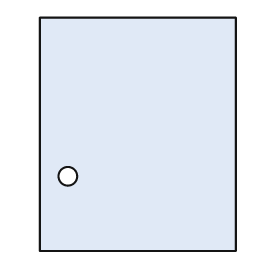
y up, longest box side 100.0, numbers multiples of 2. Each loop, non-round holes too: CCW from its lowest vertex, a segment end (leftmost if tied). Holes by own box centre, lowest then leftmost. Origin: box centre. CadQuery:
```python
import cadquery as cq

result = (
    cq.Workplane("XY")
    .moveTo(-42.0, -50.0)
    .lineTo(42.0, -50.0)
    .lineTo(42.0, 50.0)
    .lineTo(-42.0, 50.0)
    .close()
    .moveTo(-30.0, -18.0)
    .circle(4.0)
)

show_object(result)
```